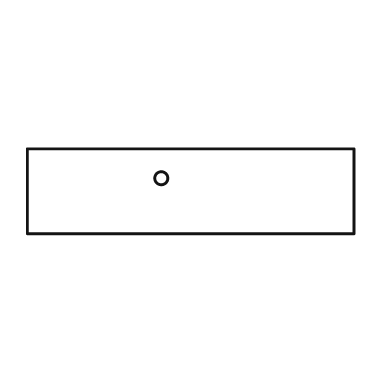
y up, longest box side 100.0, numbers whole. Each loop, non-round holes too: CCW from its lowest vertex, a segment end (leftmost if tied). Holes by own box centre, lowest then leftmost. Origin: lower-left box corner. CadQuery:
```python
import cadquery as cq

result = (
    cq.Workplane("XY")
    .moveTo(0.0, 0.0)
    .lineTo(100.0, 0.0)
    .lineTo(100.0, 26.0)
    .lineTo(0.0, 26.0)
    .close()
    .moveTo(41.0, 17.0)
    .circle(2.0)
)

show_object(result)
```